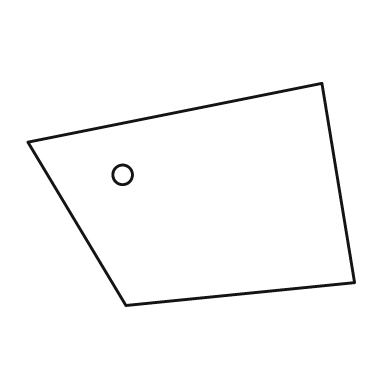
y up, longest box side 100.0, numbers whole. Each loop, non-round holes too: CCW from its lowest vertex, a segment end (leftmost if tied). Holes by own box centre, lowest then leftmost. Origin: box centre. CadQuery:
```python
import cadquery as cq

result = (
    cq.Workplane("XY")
    .moveTo(-20.0, -34.0)
    .lineTo(50.0, -27.0)
    .lineTo(40.0, 34.0)
    .lineTo(-50.0, 16.0)
    .close()
    .moveTo(-21.0, 6.0)
    .circle(3.0)
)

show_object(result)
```